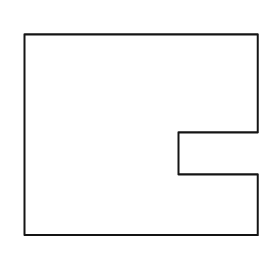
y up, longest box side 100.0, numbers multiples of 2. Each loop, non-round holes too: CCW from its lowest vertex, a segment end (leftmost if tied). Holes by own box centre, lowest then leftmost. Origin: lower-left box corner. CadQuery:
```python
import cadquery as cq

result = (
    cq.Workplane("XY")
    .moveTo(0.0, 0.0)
    .lineTo(100.0, 0.0)
    .lineTo(100.0, 26.0)
    .lineTo(66.0, 26.0)
    .lineTo(66.0, 44.0)
    .lineTo(100.0, 44.0)
    .lineTo(100.0, 86.0)
    .lineTo(0.0, 86.0)
    .close()
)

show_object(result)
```